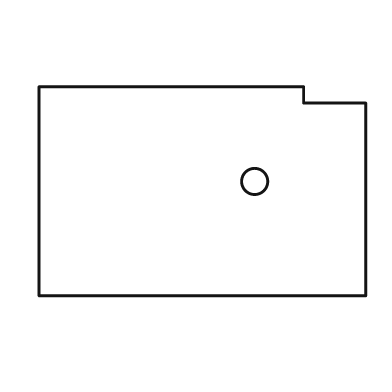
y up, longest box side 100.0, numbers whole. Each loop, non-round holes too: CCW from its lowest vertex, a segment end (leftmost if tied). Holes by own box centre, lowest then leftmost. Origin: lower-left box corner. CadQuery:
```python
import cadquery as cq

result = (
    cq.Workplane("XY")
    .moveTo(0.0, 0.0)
    .lineTo(100.0, 0.0)
    .lineTo(100.0, 59.0)
    .lineTo(81.0, 59.0)
    .lineTo(81.0, 64.0)
    .lineTo(0.0, 64.0)
    .close()
    .moveTo(66.0, 35.0)
    .circle(4.0)
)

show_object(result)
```